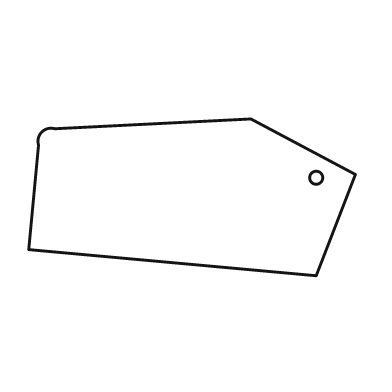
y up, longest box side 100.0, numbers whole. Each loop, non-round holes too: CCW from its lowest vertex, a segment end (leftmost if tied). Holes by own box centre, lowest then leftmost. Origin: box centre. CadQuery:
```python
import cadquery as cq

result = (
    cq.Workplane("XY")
    .moveTo(38.0, -24.0)
    .lineTo(50.0, 7.0)
    .lineTo(18.0, 24.0)
    .lineTo(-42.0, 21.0)
    .threePointArc((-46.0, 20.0), (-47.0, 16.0))
    .lineTo(-50.0, -16.0)
    .close()
    .moveTo(38.0, 6.0)
    .circle(2.0)
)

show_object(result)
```